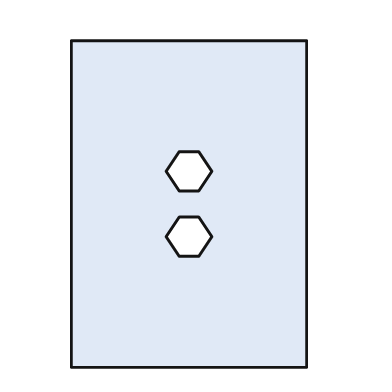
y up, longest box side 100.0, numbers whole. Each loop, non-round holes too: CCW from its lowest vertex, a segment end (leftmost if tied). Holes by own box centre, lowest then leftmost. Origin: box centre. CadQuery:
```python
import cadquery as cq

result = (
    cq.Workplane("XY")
    .moveTo(-36.0, -50.0)
    .lineTo(36.0, -50.0)
    .lineTo(36.0, 50.0)
    .lineTo(-36.0, 50.0)
    .close()
    .moveTo(-3.0, -16.0)
    .lineTo(3.0, -16.0)
    .lineTo(7.0, -10.0)
    .lineTo(3.0, -4.0)
    .lineTo(-3.0, -4.0)
    .lineTo(-7.0, -10.0)
    .close()
    .moveTo(-3.0, 4.0)
    .lineTo(3.0, 4.0)
    .lineTo(7.0, 10.0)
    .lineTo(3.0, 16.0)
    .lineTo(-3.0, 16.0)
    .lineTo(-7.0, 10.0)
    .close()
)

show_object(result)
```